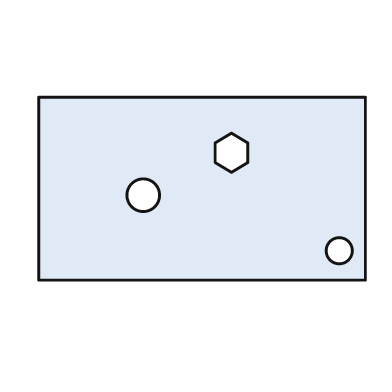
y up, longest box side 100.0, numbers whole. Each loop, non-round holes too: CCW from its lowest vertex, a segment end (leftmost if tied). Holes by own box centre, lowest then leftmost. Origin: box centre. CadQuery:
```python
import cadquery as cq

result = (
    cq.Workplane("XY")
    .moveTo(-50.0, -28.0)
    .lineTo(50.0, -28.0)
    .lineTo(50.0, 28.0)
    .lineTo(-50.0, 28.0)
    .close()
    .moveTo(42.0, -19.0)
    .circle(4.0)
    .moveTo(-18.0, -2.0)
    .circle(5.0)
    .moveTo(9.0, 5.0)
    .lineTo(14.0, 8.0)
    .lineTo(14.0, 14.0)
    .lineTo(9.0, 17.0)
    .lineTo(4.0, 14.0)
    .lineTo(4.0, 8.0)
    .close()
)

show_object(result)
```